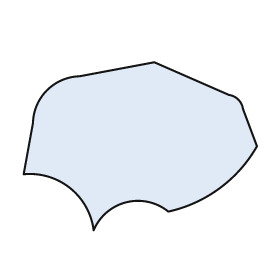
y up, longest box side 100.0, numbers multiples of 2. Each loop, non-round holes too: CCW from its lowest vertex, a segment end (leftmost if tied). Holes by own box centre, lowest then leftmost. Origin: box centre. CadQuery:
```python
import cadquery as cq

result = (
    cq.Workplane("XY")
    .moveTo(-20.0, -36.0)
    .threePointArc((-6.0, -24.0), (12.0, -28.0))
    .threePointArc((34.0, -18.0), (50.0, 0.0))
    .lineTo(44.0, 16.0)
    .threePointArc((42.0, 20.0), (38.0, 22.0))
    .lineTo(6.0, 36.0)
    .lineTo(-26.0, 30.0)
    .threePointArc((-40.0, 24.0), (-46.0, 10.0))
    .lineTo(-50.0, -12.0)
    .threePointArc((-30.0, -18.0), (-20.0, -36.0))
    .close()
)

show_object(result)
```